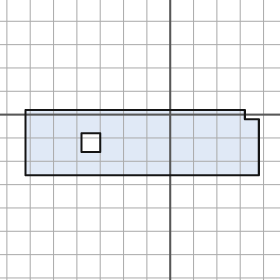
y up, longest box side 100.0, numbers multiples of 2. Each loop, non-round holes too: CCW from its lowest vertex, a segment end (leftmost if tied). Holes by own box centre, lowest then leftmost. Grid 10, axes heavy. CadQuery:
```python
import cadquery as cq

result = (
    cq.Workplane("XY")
    .moveTo(-62.0, -26.0)
    .lineTo(38.0, -26.0)
    .lineTo(38.0, -2.0)
    .lineTo(32.0, -2.0)
    .lineTo(32.0, 2.0)
    .lineTo(-62.0, 2.0)
    .close()
    .moveTo(-38.0, -16.0)
    .lineTo(-30.0, -16.0)
    .lineTo(-30.0, -8.0)
    .lineTo(-38.0, -8.0)
    .close()
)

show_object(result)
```